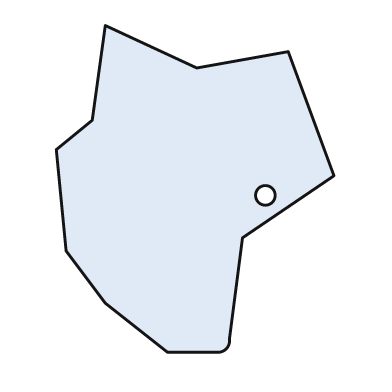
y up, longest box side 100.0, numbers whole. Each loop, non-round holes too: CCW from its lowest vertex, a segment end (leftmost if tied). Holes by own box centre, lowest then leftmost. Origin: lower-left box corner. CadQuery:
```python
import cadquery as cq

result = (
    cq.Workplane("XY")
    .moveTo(34.0, 0.0)
    .lineTo(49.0, 0.0)
    .threePointArc((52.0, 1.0), (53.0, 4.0))
    .lineTo(57.0, 35.0)
    .lineTo(85.0, 54.0)
    .lineTo(71.0, 92.0)
    .lineTo(43.0, 87.0)
    .lineTo(15.0, 100.0)
    .lineTo(11.0, 71.0)
    .lineTo(0.0, 62.0)
    .lineTo(3.0, 31.0)
    .lineTo(15.0, 15.0)
    .close()
    .moveTo(64.0, 48.0)
    .circle(3.0)
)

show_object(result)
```